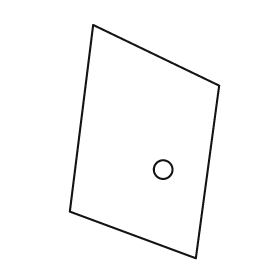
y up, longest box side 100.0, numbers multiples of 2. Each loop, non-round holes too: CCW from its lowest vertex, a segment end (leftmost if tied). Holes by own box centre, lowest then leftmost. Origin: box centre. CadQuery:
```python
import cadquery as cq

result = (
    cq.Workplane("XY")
    .moveTo(22.0, -50.0)
    .lineTo(32.0, 24.0)
    .lineTo(-22.0, 50.0)
    .lineTo(-32.0, -30.0)
    .close()
    .moveTo(8.0, -12.0)
    .circle(4.0)
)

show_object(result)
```